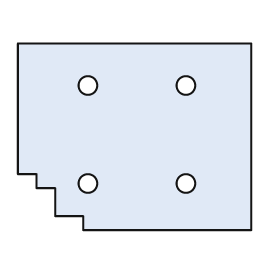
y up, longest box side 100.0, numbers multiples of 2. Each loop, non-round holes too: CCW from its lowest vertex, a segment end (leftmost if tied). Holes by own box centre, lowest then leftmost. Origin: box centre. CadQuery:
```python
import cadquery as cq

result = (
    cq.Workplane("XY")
    .moveTo(-22.0, -40.0)
    .lineTo(50.0, -40.0)
    .lineTo(50.0, 40.0)
    .lineTo(-50.0, 40.0)
    .lineTo(-50.0, -16.0)
    .lineTo(-42.0, -16.0)
    .lineTo(-42.0, -22.0)
    .lineTo(-34.0, -22.0)
    .lineTo(-34.0, -34.0)
    .lineTo(-22.0, -34.0)
    .close()
    .moveTo(-20.0, -20.0)
    .circle(4.0)
    .moveTo(22.0, -20.0)
    .circle(4.0)
    .moveTo(-20.0, 22.0)
    .circle(4.0)
    .moveTo(22.0, 22.0)
    .circle(4.0)
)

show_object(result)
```